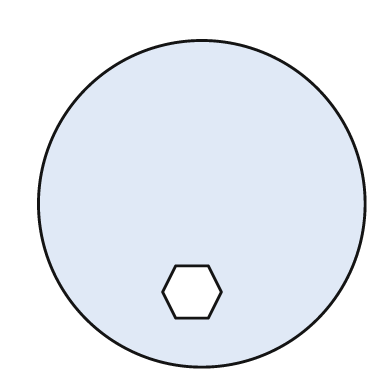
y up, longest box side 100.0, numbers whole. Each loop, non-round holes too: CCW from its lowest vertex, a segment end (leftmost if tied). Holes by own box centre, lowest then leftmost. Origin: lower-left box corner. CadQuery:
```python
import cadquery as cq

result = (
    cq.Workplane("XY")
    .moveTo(50.0, 50.0)
    .circle(50.0)
    .moveTo(42.0, 15.0)
    .lineTo(52.0, 15.0)
    .lineTo(56.0, 23.0)
    .lineTo(52.0, 31.0)
    .lineTo(42.0, 31.0)
    .lineTo(38.0, 23.0)
    .close()
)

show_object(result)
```